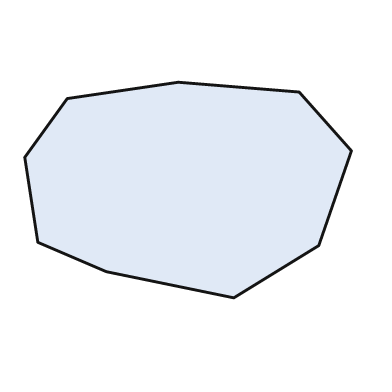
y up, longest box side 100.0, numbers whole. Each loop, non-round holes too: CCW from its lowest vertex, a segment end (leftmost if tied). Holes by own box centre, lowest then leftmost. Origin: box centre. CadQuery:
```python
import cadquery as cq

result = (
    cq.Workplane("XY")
    .moveTo(14.0, -33.0)
    .lineTo(40.0, -17.0)
    .lineTo(50.0, 12.0)
    .lineTo(34.0, 30.0)
    .lineTo(-3.0, 33.0)
    .lineTo(-37.0, 28.0)
    .lineTo(-50.0, 10.0)
    .lineTo(-46.0, -16.0)
    .lineTo(-25.0, -25.0)
    .close()
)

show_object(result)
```